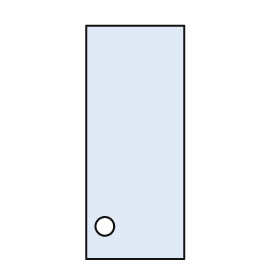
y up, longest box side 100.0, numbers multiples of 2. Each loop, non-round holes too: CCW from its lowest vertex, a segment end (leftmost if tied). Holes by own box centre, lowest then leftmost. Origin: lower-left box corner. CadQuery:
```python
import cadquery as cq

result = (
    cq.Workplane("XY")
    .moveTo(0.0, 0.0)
    .lineTo(42.0, 0.0)
    .lineTo(42.0, 100.0)
    .lineTo(0.0, 100.0)
    .close()
    .moveTo(8.0, 14.0)
    .circle(4.0)
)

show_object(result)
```